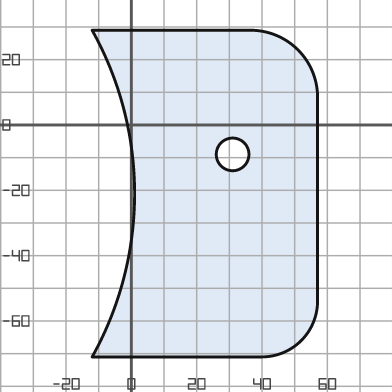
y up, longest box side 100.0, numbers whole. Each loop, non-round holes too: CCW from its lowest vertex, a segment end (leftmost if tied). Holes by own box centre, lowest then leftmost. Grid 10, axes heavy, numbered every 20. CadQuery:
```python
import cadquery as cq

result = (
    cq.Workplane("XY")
    .moveTo(-12.0, -71.0)
    .lineTo(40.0, -71.0)
    .threePointArc((52.0, -66.0), (57.0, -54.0))
    .lineTo(57.0, 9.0)
    .threePointArc((51.0, 23.0), (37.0, 29.0))
    .lineTo(-12.0, 29.0)
    .threePointArc((1.0, -21.0), (-12.0, -71.0))
    .close()
    .moveTo(31.0, -9.0)
    .circle(5.0)
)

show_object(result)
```